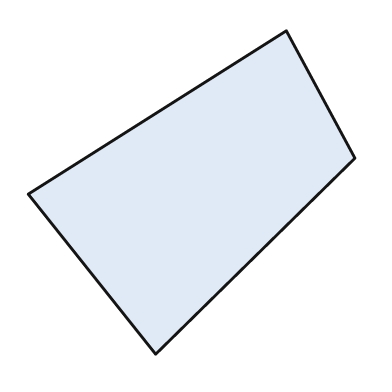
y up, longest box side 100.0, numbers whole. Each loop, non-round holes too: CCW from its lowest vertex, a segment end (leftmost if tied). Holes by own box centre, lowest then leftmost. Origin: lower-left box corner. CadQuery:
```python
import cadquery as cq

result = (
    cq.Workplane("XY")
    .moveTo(39.0, 0.0)
    .lineTo(100.0, 60.0)
    .lineTo(79.0, 99.0)
    .lineTo(0.0, 49.0)
    .close()
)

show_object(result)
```